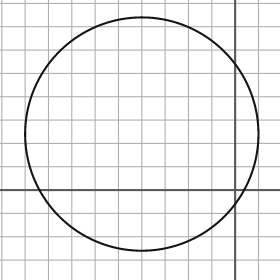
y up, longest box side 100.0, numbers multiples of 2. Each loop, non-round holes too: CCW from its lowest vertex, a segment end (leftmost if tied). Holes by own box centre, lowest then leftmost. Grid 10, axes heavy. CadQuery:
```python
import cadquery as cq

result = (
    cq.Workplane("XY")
    .moveTo(-40.0, 24.0)
    .circle(50.0)
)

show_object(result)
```